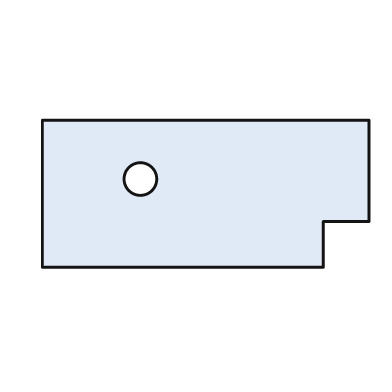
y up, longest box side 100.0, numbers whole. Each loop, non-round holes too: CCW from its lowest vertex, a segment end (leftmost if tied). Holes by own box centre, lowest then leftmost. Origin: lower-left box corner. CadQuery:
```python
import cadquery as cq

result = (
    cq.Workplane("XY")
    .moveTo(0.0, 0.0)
    .lineTo(86.0, 0.0)
    .lineTo(86.0, 14.0)
    .lineTo(100.0, 14.0)
    .lineTo(100.0, 45.0)
    .lineTo(0.0, 45.0)
    .close()
    .moveTo(30.0, 27.0)
    .circle(5.0)
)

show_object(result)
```